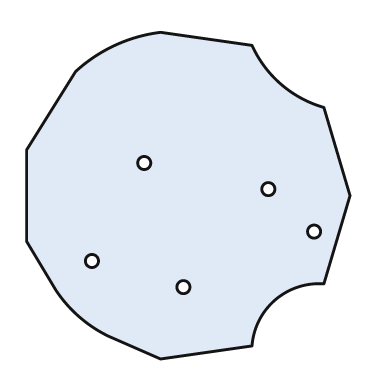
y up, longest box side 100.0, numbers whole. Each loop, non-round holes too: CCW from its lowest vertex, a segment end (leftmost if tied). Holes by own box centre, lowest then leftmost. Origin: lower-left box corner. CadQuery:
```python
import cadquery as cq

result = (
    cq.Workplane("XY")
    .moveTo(41.0, 0.0)
    .lineTo(69.0, 4.0)
    .threePointArc((76.0, 18.0), (91.0, 23.0))
    .lineTo(99.0, 50.0)
    .lineTo(91.0, 77.0)
    .threePointArc((78.0, 84.0), (69.0, 96.0))
    .lineTo(41.0, 100.0)
    .threePointArc((27.0, 96.0), (15.0, 88.0))
    .lineTo(0.0, 64.0)
    .lineTo(0.0, 36.0)
    .lineTo(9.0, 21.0)
    .threePointArc((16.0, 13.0), (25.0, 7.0))
    .close()
    .moveTo(48.0, 22.0)
    .circle(2.0)
    .moveTo(20.0, 30.0)
    .circle(2.0)
    .moveTo(88.0, 39.0)
    .circle(2.0)
    .moveTo(74.0, 52.0)
    .circle(2.0)
    .moveTo(36.0, 60.0)
    .circle(2.0)
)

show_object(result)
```